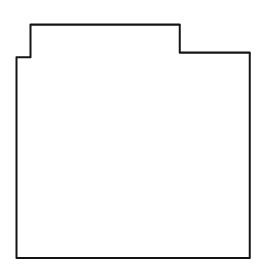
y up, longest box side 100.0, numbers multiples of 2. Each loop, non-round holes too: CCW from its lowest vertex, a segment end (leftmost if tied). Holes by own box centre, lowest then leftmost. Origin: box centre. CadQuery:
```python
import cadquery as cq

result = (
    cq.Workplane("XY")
    .moveTo(-50.0, -50.0)
    .lineTo(50.0, -50.0)
    .lineTo(50.0, 38.0)
    .lineTo(20.0, 38.0)
    .lineTo(20.0, 50.0)
    .lineTo(-44.0, 50.0)
    .lineTo(-44.0, 36.0)
    .lineTo(-50.0, 36.0)
    .close()
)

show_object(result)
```